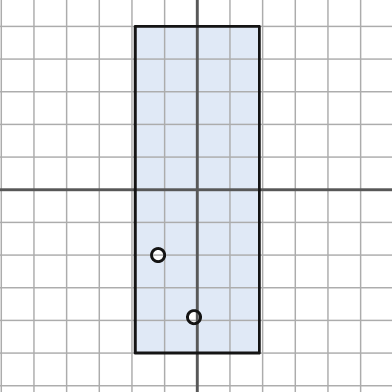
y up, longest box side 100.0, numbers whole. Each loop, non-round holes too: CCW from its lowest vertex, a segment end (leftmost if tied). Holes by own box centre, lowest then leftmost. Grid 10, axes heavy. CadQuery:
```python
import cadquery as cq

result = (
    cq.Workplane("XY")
    .moveTo(-19.0, -50.0)
    .lineTo(19.0, -50.0)
    .lineTo(19.0, 50.0)
    .lineTo(-19.0, 50.0)
    .close()
    .moveTo(-1.0, -39.0)
    .circle(2.0)
    .moveTo(-12.0, -20.0)
    .circle(2.0)
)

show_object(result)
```